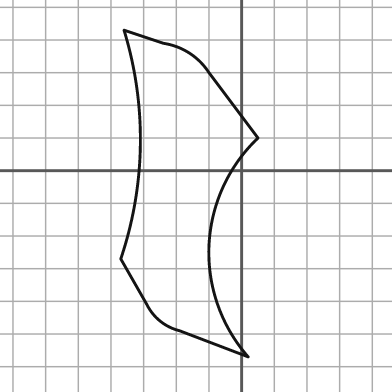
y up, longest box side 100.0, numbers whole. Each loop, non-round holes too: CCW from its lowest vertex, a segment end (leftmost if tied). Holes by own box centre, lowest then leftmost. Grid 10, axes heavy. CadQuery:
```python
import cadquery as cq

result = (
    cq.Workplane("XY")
    .moveTo(2.0, -57.0)
    .threePointArc((-10.0, -23.0), (5.0, 10.0))
    .lineTo(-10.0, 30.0)
    .threePointArc((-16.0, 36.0), (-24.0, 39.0))
    .lineTo(-36.0, 43.0)
    .threePointArc((-31.0, 8.0), (-37.0, -27.0))
    .lineTo(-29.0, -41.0)
    .threePointArc((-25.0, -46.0), (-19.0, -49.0))
    .close()
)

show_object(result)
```